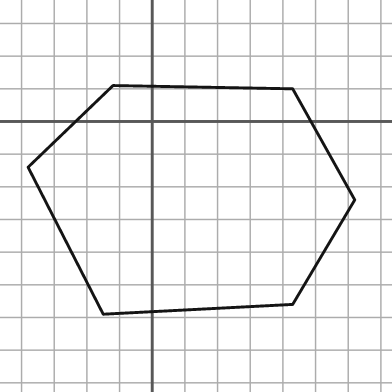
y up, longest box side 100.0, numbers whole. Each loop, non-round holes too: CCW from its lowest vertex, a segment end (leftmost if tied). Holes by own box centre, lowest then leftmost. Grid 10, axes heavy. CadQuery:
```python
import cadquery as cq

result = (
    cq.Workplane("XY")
    .moveTo(-15.0, -59.0)
    .lineTo(43.0, -56.0)
    .lineTo(62.0, -24.0)
    .lineTo(43.0, 10.0)
    .lineTo(-12.0, 11.0)
    .lineTo(-38.0, -14.0)
    .close()
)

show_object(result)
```